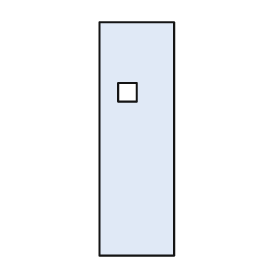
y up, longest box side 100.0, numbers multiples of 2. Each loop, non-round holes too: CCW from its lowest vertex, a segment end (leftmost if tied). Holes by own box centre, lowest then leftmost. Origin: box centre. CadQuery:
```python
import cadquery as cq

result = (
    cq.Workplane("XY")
    .moveTo(-16.0, -50.0)
    .lineTo(16.0, -50.0)
    .lineTo(16.0, 50.0)
    .lineTo(-16.0, 50.0)
    .close()
    .moveTo(-8.0, 16.0)
    .lineTo(0.0, 16.0)
    .lineTo(0.0, 24.0)
    .lineTo(-8.0, 24.0)
    .close()
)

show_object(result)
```